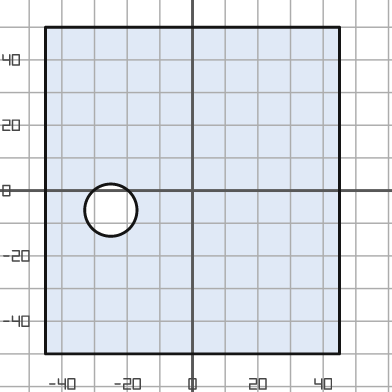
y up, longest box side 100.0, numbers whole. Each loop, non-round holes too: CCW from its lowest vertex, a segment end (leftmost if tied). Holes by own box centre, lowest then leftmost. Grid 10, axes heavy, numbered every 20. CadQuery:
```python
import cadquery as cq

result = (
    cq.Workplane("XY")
    .moveTo(-45.0, -50.0)
    .lineTo(45.0, -50.0)
    .lineTo(45.0, 50.0)
    .lineTo(-45.0, 50.0)
    .close()
    .moveTo(-25.0, -6.0)
    .circle(8.0)
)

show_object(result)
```